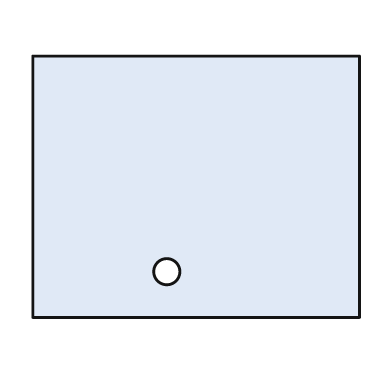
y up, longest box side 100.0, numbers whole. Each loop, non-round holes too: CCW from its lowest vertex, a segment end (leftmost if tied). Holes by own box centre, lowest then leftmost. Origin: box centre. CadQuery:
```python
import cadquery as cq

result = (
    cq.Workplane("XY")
    .moveTo(-50.0, -40.0)
    .lineTo(50.0, -40.0)
    .lineTo(50.0, 40.0)
    .lineTo(-50.0, 40.0)
    .close()
    .moveTo(-9.0, -26.0)
    .circle(4.0)
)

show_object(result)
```